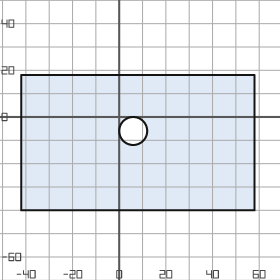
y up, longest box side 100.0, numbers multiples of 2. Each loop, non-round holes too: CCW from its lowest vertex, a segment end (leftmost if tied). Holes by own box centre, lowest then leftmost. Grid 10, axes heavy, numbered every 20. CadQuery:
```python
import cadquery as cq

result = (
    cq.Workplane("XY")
    .moveTo(-42.0, -40.0)
    .lineTo(58.0, -40.0)
    .lineTo(58.0, 18.0)
    .lineTo(-42.0, 18.0)
    .close()
    .moveTo(6.0, -6.0)
    .circle(6.0)
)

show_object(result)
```